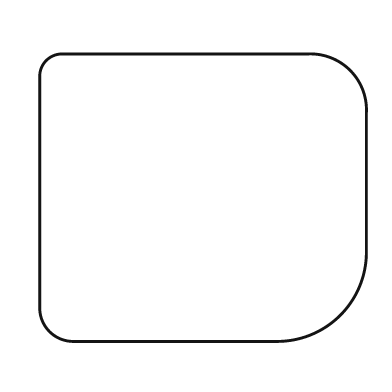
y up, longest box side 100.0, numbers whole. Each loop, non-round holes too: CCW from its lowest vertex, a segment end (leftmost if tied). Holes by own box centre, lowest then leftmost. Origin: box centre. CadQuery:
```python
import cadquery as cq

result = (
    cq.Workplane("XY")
    .moveTo(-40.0, -44.0)
    .lineTo(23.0, -44.0)
    .threePointArc((42.0, -36.0), (50.0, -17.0))
    .lineTo(50.0, 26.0)
    .threePointArc((45.0, 39.0), (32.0, 44.0))
    .lineTo(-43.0, 44.0)
    .threePointArc((-48.0, 42.0), (-50.0, 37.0))
    .lineTo(-50.0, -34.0)
    .threePointArc((-47.0, -41.0), (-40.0, -44.0))
    .close()
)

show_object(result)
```